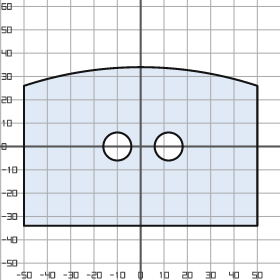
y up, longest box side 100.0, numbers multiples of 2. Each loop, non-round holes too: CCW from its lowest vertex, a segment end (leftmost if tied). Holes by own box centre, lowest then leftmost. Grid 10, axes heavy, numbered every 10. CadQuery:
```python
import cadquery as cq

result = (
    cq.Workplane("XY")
    .moveTo(-50.0, -34.0)
    .lineTo(50.0, -34.0)
    .lineTo(50.0, 26.0)
    .threePointArc((0.0, 34.0), (-50.0, 26.0))
    .close()
    .moveTo(-10.0, 0.0)
    .circle(6.0)
    .moveTo(12.0, 0.0)
    .circle(6.0)
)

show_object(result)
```